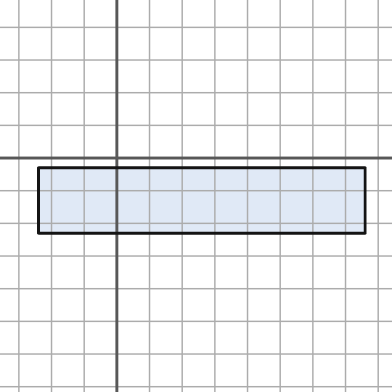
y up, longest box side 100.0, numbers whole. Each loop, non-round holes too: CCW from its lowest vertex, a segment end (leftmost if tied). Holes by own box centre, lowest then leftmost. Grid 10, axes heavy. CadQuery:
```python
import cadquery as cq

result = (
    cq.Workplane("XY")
    .moveTo(-24.0, -23.0)
    .lineTo(76.0, -23.0)
    .lineTo(76.0, -3.0)
    .lineTo(-24.0, -3.0)
    .close()
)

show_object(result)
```